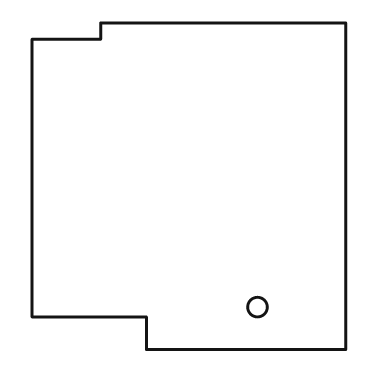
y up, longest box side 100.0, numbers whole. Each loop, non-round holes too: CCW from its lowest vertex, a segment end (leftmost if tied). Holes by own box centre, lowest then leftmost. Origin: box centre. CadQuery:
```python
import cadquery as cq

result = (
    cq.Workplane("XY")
    .moveTo(-13.0, -50.0)
    .lineTo(48.0, -50.0)
    .lineTo(48.0, 50.0)
    .lineTo(-27.0, 50.0)
    .lineTo(-27.0, 45.0)
    .lineTo(-48.0, 45.0)
    .lineTo(-48.0, -40.0)
    .lineTo(-13.0, -40.0)
    .close()
    .moveTo(21.0, -37.0)
    .circle(3.0)
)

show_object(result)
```